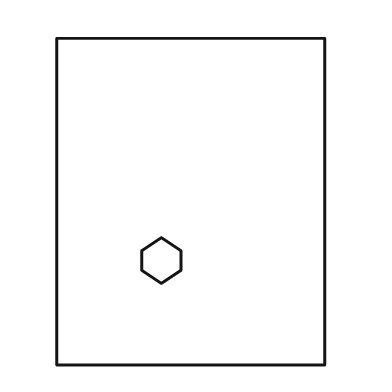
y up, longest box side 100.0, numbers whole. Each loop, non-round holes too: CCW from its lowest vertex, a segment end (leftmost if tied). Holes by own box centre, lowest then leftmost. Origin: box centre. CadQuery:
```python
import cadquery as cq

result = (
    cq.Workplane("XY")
    .moveTo(-41.0, -50.0)
    .lineTo(41.0, -50.0)
    .lineTo(41.0, 50.0)
    .lineTo(-41.0, 50.0)
    .close()
    .moveTo(-9.0, -25.0)
    .lineTo(-3.0, -21.0)
    .lineTo(-3.0, -15.0)
    .lineTo(-9.0, -11.0)
    .lineTo(-15.0, -15.0)
    .lineTo(-15.0, -21.0)
    .close()
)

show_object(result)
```